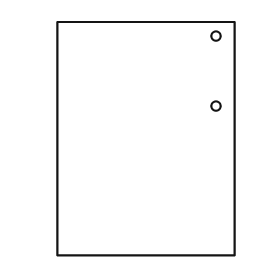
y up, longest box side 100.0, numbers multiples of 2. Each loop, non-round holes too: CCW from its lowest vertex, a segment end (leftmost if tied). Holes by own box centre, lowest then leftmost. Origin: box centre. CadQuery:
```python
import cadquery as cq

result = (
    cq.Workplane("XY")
    .moveTo(-38.0, -50.0)
    .lineTo(38.0, -50.0)
    .lineTo(38.0, 50.0)
    .lineTo(-38.0, 50.0)
    .close()
    .moveTo(30.0, 14.0)
    .circle(2.0)
    .moveTo(30.0, 44.0)
    .circle(2.0)
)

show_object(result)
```